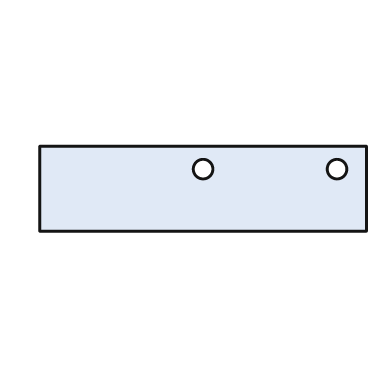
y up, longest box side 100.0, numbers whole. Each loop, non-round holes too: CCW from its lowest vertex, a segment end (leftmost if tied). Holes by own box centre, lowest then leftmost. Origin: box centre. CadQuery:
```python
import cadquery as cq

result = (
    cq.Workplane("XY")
    .moveTo(-50.0, -13.0)
    .lineTo(50.0, -13.0)
    .lineTo(50.0, 13.0)
    .lineTo(-50.0, 13.0)
    .close()
    .moveTo(0.0, 6.0)
    .circle(3.0)
    .moveTo(41.0, 6.0)
    .circle(3.0)
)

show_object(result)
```